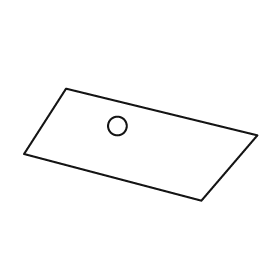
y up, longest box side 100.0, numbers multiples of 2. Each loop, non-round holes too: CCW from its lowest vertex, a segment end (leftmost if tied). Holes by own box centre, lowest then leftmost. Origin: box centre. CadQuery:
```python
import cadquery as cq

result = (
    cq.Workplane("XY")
    .moveTo(26.0, -24.0)
    .lineTo(50.0, 4.0)
    .lineTo(-32.0, 24.0)
    .lineTo(-50.0, -4.0)
    .close()
    .moveTo(-10.0, 8.0)
    .circle(4.0)
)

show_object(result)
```